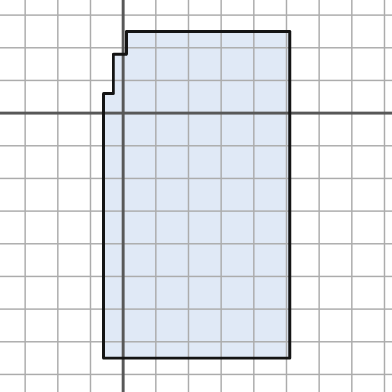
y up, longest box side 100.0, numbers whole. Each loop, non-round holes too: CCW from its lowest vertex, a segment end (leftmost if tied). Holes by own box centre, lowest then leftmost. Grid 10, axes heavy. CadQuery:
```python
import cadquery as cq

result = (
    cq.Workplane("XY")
    .moveTo(-6.0, -75.0)
    .lineTo(51.0, -75.0)
    .lineTo(51.0, 25.0)
    .lineTo(1.0, 25.0)
    .lineTo(1.0, 18.0)
    .lineTo(-3.0, 18.0)
    .lineTo(-3.0, 6.0)
    .lineTo(-6.0, 6.0)
    .close()
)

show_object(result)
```